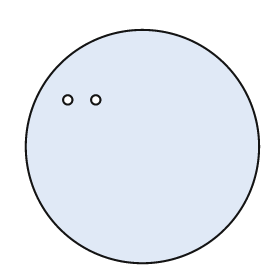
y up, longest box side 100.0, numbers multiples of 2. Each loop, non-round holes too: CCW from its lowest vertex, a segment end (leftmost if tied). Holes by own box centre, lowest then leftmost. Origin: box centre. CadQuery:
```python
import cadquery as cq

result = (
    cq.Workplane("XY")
    .moveTo(0.0, 0.0)
    .circle(50.0)
    .moveTo(-32.0, 20.0)
    .circle(2.0)
    .moveTo(-20.0, 20.0)
    .circle(2.0)
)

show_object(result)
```